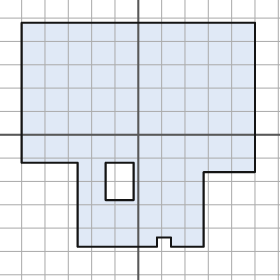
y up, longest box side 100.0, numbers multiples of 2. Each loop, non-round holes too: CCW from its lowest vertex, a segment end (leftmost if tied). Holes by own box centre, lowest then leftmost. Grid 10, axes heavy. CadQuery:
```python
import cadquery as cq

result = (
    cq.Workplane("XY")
    .moveTo(-26.0, -48.0)
    .lineTo(8.0, -48.0)
    .lineTo(8.0, -44.0)
    .lineTo(14.0, -44.0)
    .lineTo(14.0, -48.0)
    .lineTo(28.0, -48.0)
    .lineTo(28.0, -16.0)
    .lineTo(50.0, -16.0)
    .lineTo(50.0, 48.0)
    .lineTo(-50.0, 48.0)
    .lineTo(-50.0, -12.0)
    .lineTo(-26.0, -12.0)
    .close()
    .moveTo(-14.0, -28.0)
    .lineTo(-2.0, -28.0)
    .lineTo(-2.0, -12.0)
    .lineTo(-14.0, -12.0)
    .close()
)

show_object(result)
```